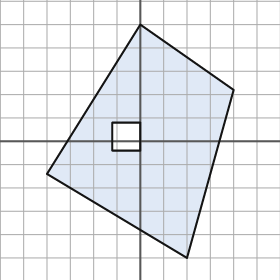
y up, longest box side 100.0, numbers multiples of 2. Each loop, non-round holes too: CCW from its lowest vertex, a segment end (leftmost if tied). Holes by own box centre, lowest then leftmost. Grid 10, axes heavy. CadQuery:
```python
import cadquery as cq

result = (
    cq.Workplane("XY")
    .moveTo(20.0, -50.0)
    .lineTo(40.0, 22.0)
    .lineTo(0.0, 50.0)
    .lineTo(-40.0, -14.0)
    .close()
    .moveTo(-12.0, -4.0)
    .lineTo(0.0, -4.0)
    .lineTo(0.0, 8.0)
    .lineTo(-12.0, 8.0)
    .close()
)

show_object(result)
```